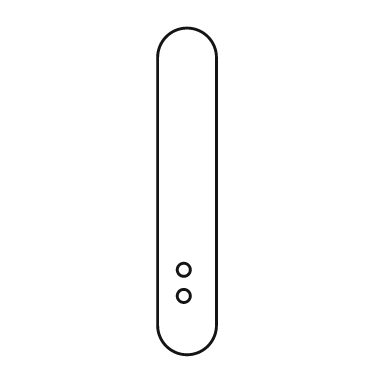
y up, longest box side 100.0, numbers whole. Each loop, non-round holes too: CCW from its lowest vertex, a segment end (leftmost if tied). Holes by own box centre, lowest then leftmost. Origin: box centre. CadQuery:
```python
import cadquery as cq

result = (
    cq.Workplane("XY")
    .moveTo(-9.0, -41.0)
    .threePointArc((0.0, -50.0), (9.0, -41.0))
    .lineTo(9.0, 41.0)
    .threePointArc((0.0, 50.0), (-9.0, 41.0))
    .close()
    .moveTo(-1.0, -32.0)
    .circle(2.0)
    .moveTo(-1.0, -24.0)
    .circle(2.0)
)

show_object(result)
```